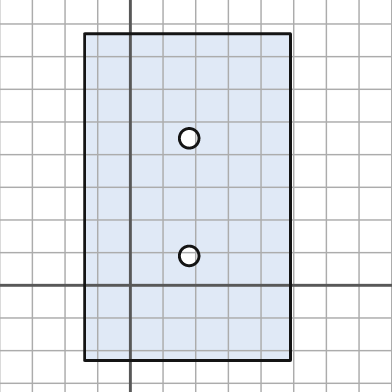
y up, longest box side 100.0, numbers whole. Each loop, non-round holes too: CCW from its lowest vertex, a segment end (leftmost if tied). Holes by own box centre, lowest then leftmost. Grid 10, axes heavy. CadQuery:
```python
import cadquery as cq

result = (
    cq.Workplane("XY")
    .moveTo(-14.0, -23.0)
    .lineTo(49.0, -23.0)
    .lineTo(49.0, 77.0)
    .lineTo(-14.0, 77.0)
    .close()
    .moveTo(18.0, 9.0)
    .circle(3.0)
    .moveTo(18.0, 45.0)
    .circle(3.0)
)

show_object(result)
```